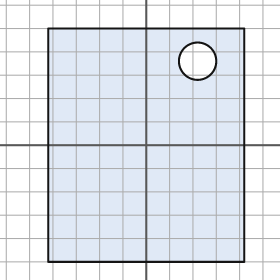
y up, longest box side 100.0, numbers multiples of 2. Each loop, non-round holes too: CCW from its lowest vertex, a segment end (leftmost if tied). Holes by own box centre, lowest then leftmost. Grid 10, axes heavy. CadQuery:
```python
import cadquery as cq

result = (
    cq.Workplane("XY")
    .moveTo(-42.0, -50.0)
    .lineTo(42.0, -50.0)
    .lineTo(42.0, 50.0)
    .lineTo(-42.0, 50.0)
    .close()
    .moveTo(22.0, 36.0)
    .circle(8.0)
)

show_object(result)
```